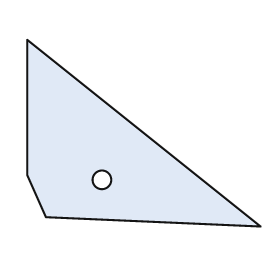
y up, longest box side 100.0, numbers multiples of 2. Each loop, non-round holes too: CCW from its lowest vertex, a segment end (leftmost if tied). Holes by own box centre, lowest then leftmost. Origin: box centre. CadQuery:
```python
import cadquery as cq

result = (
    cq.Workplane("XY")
    .moveTo(50.0, -40.0)
    .lineTo(-50.0, 40.0)
    .lineTo(-50.0, -18.0)
    .lineTo(-42.0, -36.0)
    .close()
    .moveTo(-18.0, -20.0)
    .circle(4.0)
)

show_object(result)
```